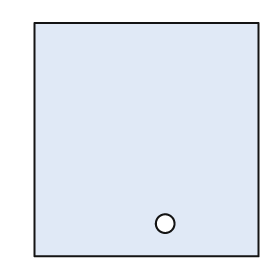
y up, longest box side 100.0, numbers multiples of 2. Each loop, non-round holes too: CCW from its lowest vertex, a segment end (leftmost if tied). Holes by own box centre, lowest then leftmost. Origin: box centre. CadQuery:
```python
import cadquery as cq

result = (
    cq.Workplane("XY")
    .moveTo(-48.0, -50.0)
    .lineTo(48.0, -50.0)
    .lineTo(48.0, 50.0)
    .lineTo(-48.0, 50.0)
    .close()
    .moveTo(8.0, -36.0)
    .circle(4.0)
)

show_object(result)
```